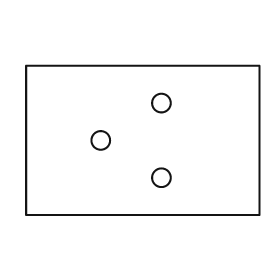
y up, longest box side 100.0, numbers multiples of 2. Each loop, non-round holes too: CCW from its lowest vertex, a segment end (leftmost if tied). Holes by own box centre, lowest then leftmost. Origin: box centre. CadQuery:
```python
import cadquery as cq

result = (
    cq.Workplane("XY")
    .moveTo(-50.0, -32.0)
    .lineTo(50.0, -32.0)
    .lineTo(50.0, 32.0)
    .lineTo(-50.0, 32.0)
    .close()
    .moveTo(8.0, -16.0)
    .circle(4.0)
    .moveTo(-18.0, 0.0)
    .circle(4.0)
    .moveTo(8.0, 16.0)
    .circle(4.0)
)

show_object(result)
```